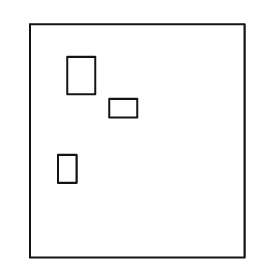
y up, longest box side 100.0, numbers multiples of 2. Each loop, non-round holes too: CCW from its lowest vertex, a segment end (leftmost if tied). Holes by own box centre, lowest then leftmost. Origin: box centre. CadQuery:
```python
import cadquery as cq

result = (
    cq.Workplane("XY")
    .moveTo(-46.0, -50.0)
    .lineTo(46.0, -50.0)
    .lineTo(46.0, 50.0)
    .lineTo(-46.0, 50.0)
    .close()
    .moveTo(-34.0, -18.0)
    .lineTo(-26.0, -18.0)
    .lineTo(-26.0, -6.0)
    .lineTo(-34.0, -6.0)
    .close()
    .moveTo(-12.0, 10.0)
    .lineTo(0.0, 10.0)
    .lineTo(0.0, 18.0)
    .lineTo(-12.0, 18.0)
    .close()
    .moveTo(-30.0, 20.0)
    .lineTo(-18.0, 20.0)
    .lineTo(-18.0, 36.0)
    .lineTo(-30.0, 36.0)
    .close()
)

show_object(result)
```